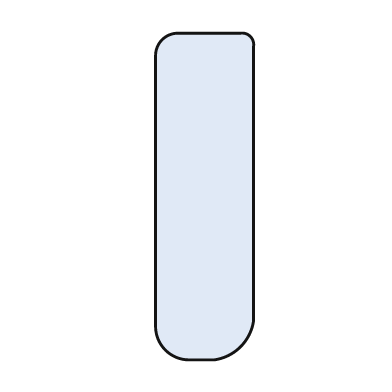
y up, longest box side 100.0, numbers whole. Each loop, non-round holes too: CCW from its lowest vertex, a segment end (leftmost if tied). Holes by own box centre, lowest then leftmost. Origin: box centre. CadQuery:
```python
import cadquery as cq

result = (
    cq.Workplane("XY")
    .moveTo(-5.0, -50.0)
    .lineTo(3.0, -50.0)
    .threePointArc((11.0, -46.0), (15.0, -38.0))
    .lineTo(15.0, 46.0)
    .threePointArc((14.0, 49.0), (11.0, 50.0))
    .lineTo(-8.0, 50.0)
    .threePointArc((-13.0, 48.0), (-15.0, 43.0))
    .lineTo(-15.0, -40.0)
    .threePointArc((-12.0, -47.0), (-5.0, -50.0))
    .close()
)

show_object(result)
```